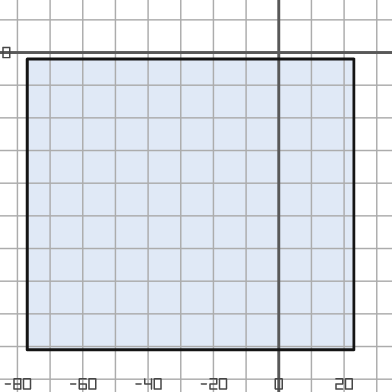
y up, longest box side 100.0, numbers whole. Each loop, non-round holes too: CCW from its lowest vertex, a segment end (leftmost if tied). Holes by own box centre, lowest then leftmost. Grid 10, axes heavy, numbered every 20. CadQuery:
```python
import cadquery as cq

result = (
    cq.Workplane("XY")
    .moveTo(-77.0, -91.0)
    .lineTo(23.0, -91.0)
    .lineTo(23.0, -2.0)
    .lineTo(-77.0, -2.0)
    .close()
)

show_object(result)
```